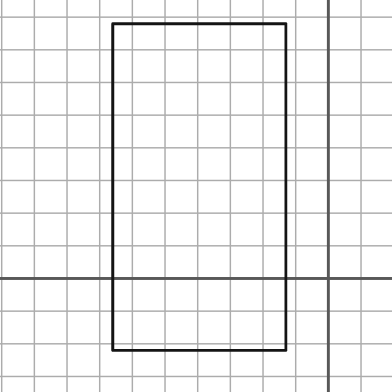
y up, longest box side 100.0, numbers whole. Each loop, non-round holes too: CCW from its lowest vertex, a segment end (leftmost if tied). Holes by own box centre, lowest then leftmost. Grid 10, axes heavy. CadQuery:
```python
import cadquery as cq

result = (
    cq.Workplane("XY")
    .moveTo(-66.0, -22.0)
    .lineTo(-13.0, -22.0)
    .lineTo(-13.0, 78.0)
    .lineTo(-66.0, 78.0)
    .close()
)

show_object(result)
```